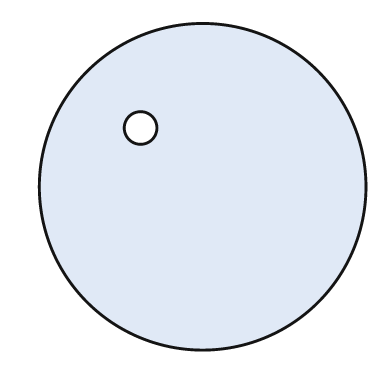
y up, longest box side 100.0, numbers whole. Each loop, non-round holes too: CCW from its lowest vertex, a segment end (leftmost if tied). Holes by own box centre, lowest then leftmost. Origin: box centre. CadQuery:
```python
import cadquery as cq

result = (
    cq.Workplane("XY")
    .moveTo(0.0, 0.0)
    .circle(50.0)
    .moveTo(-19.0, 18.0)
    .circle(5.0)
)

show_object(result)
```